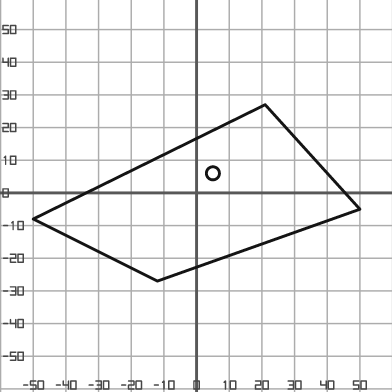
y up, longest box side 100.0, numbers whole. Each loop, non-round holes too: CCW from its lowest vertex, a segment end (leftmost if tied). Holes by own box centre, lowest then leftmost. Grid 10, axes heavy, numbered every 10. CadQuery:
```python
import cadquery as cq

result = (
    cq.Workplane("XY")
    .moveTo(-12.0, -27.0)
    .lineTo(50.0, -5.0)
    .lineTo(21.0, 27.0)
    .lineTo(-50.0, -8.0)
    .close()
    .moveTo(5.0, 6.0)
    .circle(2.0)
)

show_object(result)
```